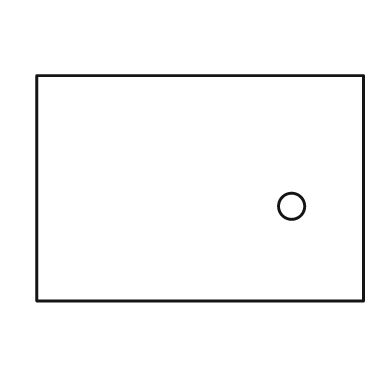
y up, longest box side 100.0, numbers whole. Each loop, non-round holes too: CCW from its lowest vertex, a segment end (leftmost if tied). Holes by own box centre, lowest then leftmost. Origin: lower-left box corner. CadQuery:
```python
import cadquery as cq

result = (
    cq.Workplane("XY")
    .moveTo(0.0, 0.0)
    .lineTo(100.0, 0.0)
    .lineTo(100.0, 69.0)
    .lineTo(0.0, 69.0)
    .close()
    .moveTo(78.0, 29.0)
    .circle(4.0)
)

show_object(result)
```